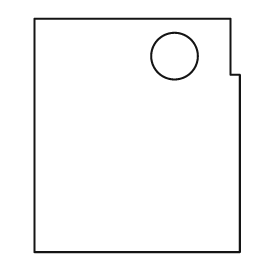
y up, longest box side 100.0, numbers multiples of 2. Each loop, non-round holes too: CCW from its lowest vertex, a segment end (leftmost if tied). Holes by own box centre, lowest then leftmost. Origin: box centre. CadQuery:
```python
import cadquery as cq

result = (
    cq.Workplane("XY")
    .moveTo(-44.0, -50.0)
    .lineTo(44.0, -50.0)
    .lineTo(44.0, 26.0)
    .lineTo(40.0, 26.0)
    .lineTo(40.0, 50.0)
    .lineTo(-44.0, 50.0)
    .close()
    .moveTo(16.0, 34.0)
    .circle(10.0)
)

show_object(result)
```